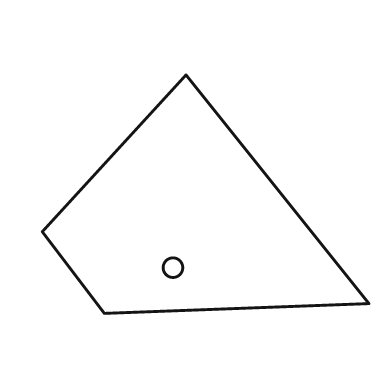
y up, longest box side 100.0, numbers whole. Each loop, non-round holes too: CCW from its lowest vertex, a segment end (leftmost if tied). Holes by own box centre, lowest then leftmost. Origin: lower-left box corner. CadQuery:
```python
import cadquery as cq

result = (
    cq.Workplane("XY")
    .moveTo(19.0, 0.0)
    .lineTo(100.0, 3.0)
    .lineTo(44.0, 73.0)
    .lineTo(0.0, 25.0)
    .close()
    .moveTo(40.0, 14.0)
    .circle(3.0)
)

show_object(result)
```